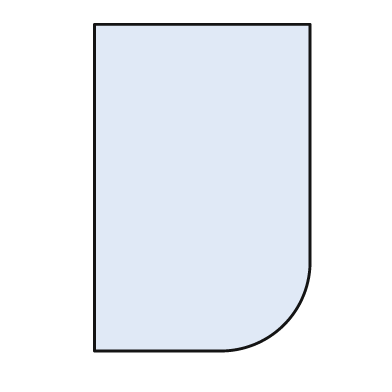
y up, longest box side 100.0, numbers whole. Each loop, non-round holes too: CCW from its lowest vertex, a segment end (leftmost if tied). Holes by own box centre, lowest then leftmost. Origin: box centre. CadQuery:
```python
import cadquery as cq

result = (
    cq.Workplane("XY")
    .moveTo(-33.0, -50.0)
    .lineTo(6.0, -50.0)
    .threePointArc((25.0, -42.0), (33.0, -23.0))
    .lineTo(33.0, 50.0)
    .lineTo(-33.0, 50.0)
    .close()
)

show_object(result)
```